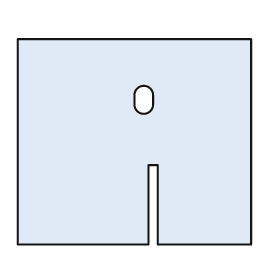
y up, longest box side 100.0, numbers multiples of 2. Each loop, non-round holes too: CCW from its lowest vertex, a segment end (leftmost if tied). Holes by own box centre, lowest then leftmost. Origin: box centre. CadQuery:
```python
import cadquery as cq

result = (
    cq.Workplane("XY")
    .moveTo(-50.0, -44.0)
    .lineTo(6.0, -44.0)
    .lineTo(6.0, -10.0)
    .lineTo(10.0, -10.0)
    .lineTo(10.0, -44.0)
    .lineTo(50.0, -44.0)
    .lineTo(50.0, 44.0)
    .lineTo(-50.0, 44.0)
    .close()
    .moveTo(0.0, 16.0)
    .threePointArc((4.0, 12.0), (8.0, 16.0))
    .lineTo(8.0, 20.0)
    .threePointArc((4.0, 24.0), (0.0, 20.0))
    .close()
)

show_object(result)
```